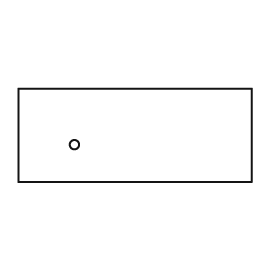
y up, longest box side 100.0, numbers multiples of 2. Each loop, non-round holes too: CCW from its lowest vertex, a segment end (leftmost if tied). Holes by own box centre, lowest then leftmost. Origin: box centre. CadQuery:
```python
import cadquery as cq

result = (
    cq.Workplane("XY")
    .moveTo(-50.0, -20.0)
    .lineTo(50.0, -20.0)
    .lineTo(50.0, 20.0)
    .lineTo(-50.0, 20.0)
    .close()
    .moveTo(-26.0, -4.0)
    .circle(2.0)
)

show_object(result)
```